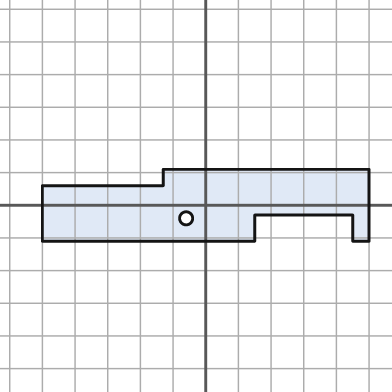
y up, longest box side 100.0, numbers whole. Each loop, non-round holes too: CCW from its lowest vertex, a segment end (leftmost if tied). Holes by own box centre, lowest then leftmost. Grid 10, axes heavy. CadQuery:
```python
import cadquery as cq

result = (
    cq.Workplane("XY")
    .moveTo(-50.0, -11.0)
    .lineTo(15.0, -11.0)
    .lineTo(15.0, -3.0)
    .lineTo(45.0, -3.0)
    .lineTo(45.0, -11.0)
    .lineTo(50.0, -11.0)
    .lineTo(50.0, 11.0)
    .lineTo(-13.0, 11.0)
    .lineTo(-13.0, 6.0)
    .lineTo(-50.0, 6.0)
    .close()
    .moveTo(-6.0, -4.0)
    .circle(2.0)
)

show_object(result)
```